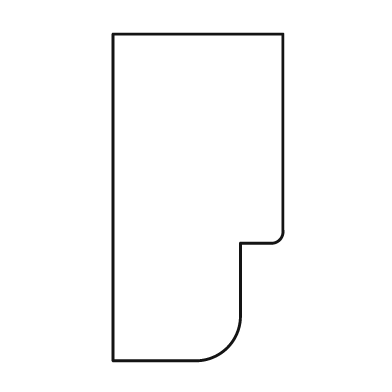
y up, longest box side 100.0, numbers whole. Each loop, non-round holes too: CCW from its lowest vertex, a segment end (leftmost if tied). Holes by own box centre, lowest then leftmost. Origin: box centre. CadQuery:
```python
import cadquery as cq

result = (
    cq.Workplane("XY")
    .moveTo(-26.0, -50.0)
    .lineTo(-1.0, -50.0)
    .threePointArc((9.0, -46.0), (13.0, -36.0))
    .lineTo(13.0, -14.0)
    .lineTo(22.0, -14.0)
    .threePointArc((25.0, -13.0), (26.0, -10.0))
    .lineTo(26.0, 50.0)
    .lineTo(-26.0, 50.0)
    .close()
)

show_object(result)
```